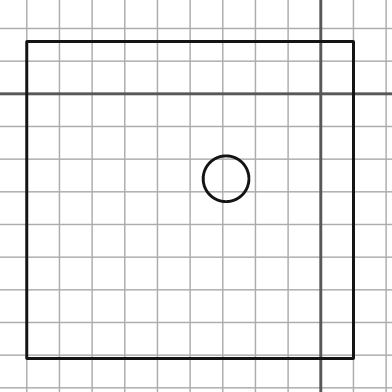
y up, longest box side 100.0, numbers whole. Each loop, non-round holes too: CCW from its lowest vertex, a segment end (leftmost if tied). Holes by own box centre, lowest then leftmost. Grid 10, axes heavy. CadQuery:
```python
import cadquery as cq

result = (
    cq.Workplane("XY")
    .moveTo(-90.0, -81.0)
    .lineTo(10.0, -81.0)
    .lineTo(10.0, 16.0)
    .lineTo(-90.0, 16.0)
    .close()
    .moveTo(-29.0, -26.0)
    .circle(7.0)
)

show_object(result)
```